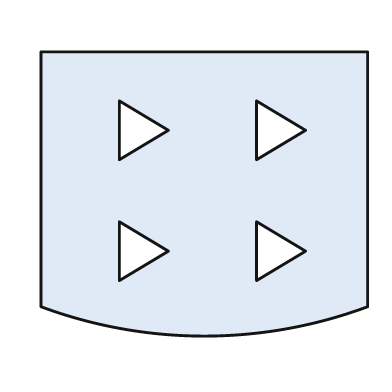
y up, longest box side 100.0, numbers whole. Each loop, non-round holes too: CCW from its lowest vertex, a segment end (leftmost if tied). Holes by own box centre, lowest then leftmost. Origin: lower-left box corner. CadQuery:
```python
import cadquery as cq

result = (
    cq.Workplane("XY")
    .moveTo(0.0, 9.0)
    .threePointArc((50.0, 0.0), (100.0, 9.0))
    .lineTo(100.0, 87.0)
    .lineTo(0.0, 87.0)
    .close()
    .moveTo(24.0, 17.0)
    .lineTo(39.0, 26.0)
    .lineTo(24.0, 35.0)
    .close()
    .moveTo(66.0, 17.0)
    .lineTo(81.0, 26.0)
    .lineTo(66.0, 35.0)
    .close()
    .moveTo(24.0, 54.0)
    .lineTo(39.0, 63.0)
    .lineTo(24.0, 72.0)
    .close()
    .moveTo(66.0, 54.0)
    .lineTo(81.0, 63.0)
    .lineTo(66.0, 72.0)
    .close()
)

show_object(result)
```